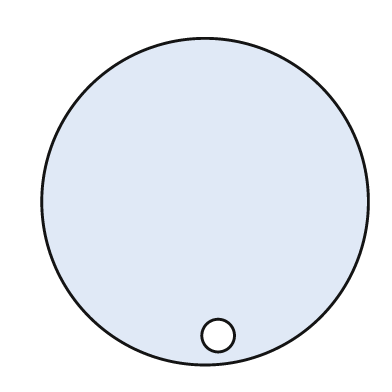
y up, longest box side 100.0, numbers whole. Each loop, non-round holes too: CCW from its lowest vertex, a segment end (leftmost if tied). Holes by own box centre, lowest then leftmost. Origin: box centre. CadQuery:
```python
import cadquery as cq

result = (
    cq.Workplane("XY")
    .moveTo(0.0, 0.0)
    .circle(50.0)
    .moveTo(4.0, -41.0)
    .circle(5.0)
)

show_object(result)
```